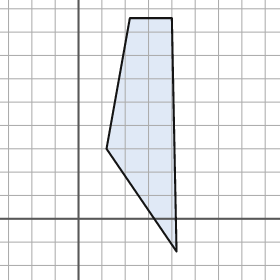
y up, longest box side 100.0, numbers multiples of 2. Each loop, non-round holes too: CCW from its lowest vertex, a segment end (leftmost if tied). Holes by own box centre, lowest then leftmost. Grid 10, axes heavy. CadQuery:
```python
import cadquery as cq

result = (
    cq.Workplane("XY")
    .moveTo(42.0, -14.0)
    .lineTo(40.0, 86.0)
    .lineTo(22.0, 86.0)
    .lineTo(12.0, 30.0)
    .close()
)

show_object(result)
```